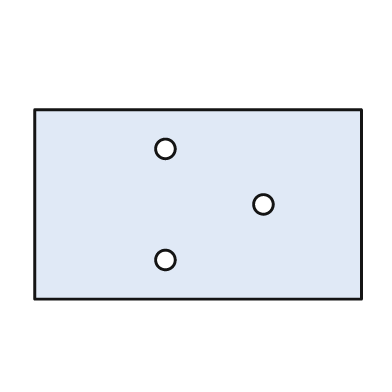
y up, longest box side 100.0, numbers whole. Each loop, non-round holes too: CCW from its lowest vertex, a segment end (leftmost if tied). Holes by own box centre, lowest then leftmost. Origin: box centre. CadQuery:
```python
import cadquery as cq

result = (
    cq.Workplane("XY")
    .moveTo(-50.0, -29.0)
    .lineTo(50.0, -29.0)
    .lineTo(50.0, 29.0)
    .lineTo(-50.0, 29.0)
    .close()
    .moveTo(-10.0, -17.0)
    .circle(3.0)
    .moveTo(20.0, 0.0)
    .circle(3.0)
    .moveTo(-10.0, 17.0)
    .circle(3.0)
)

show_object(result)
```